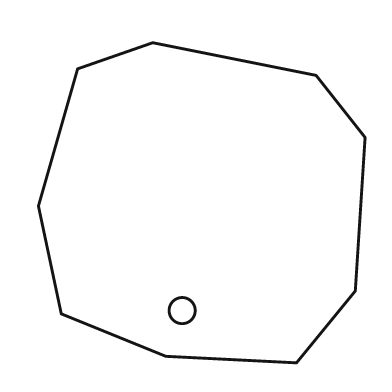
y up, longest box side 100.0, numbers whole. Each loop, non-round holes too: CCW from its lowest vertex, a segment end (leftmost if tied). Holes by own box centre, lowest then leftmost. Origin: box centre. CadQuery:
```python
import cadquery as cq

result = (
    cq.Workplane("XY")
    .moveTo(29.0, -49.0)
    .lineTo(47.0, -27.0)
    .lineTo(50.0, 20.0)
    .lineTo(35.0, 39.0)
    .lineTo(-15.0, 49.0)
    .lineTo(-38.0, 41.0)
    .lineTo(-50.0, -1.0)
    .lineTo(-43.0, -34.0)
    .lineTo(-11.0, -47.0)
    .close()
    .moveTo(-6.0, -33.0)
    .circle(4.0)
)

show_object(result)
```